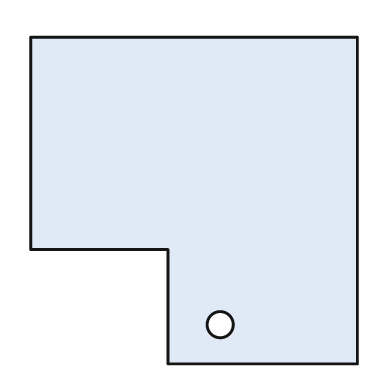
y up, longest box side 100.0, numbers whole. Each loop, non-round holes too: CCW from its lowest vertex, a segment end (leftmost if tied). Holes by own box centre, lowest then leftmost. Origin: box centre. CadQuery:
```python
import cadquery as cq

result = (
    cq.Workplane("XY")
    .moveTo(-8.0, -50.0)
    .lineTo(50.0, -50.0)
    .lineTo(50.0, 50.0)
    .lineTo(-50.0, 50.0)
    .lineTo(-50.0, -15.0)
    .lineTo(-8.0, -15.0)
    .close()
    .moveTo(8.0, -38.0)
    .circle(4.0)
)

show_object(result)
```